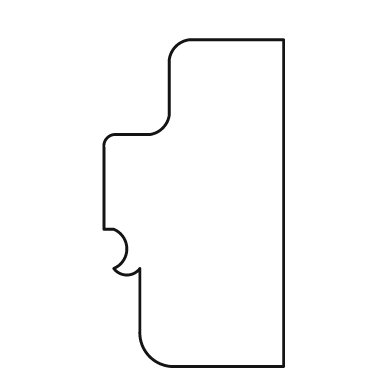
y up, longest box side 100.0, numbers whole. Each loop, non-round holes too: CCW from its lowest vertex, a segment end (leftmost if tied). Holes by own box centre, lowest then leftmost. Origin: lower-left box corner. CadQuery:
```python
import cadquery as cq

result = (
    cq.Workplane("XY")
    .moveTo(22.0, 0.0)
    .lineTo(55.0, 0.0)
    .lineTo(55.0, 100.0)
    .lineTo(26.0, 100.0)
    .threePointArc((22.0, 98.0), (20.0, 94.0))
    .lineTo(20.0, 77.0)
    .threePointArc((18.0, 73.0), (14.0, 71.0))
    .lineTo(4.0, 71.0)
    .threePointArc((1.0, 70.0), (0.0, 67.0))
    .lineTo(0.0, 42.0)
    .lineTo(3.0, 42.0)
    .threePointArc((7.0, 36.0), (3.0, 30.0))
    .threePointArc((7.0, 28.0), (11.0, 30.0))
    .lineTo(11.0, 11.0)
    .threePointArc((14.0, 3.0), (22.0, 0.0))
    .close()
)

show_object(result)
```